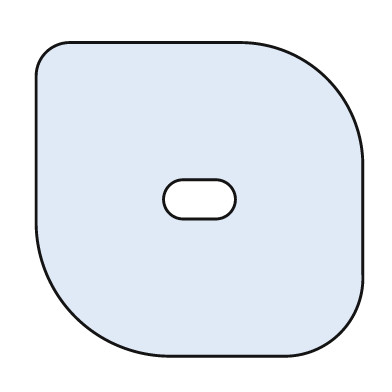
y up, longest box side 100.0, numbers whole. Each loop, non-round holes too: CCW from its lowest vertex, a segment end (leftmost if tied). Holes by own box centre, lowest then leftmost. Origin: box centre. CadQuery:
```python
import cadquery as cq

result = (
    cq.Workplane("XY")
    .moveTo(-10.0, -48.0)
    .lineTo(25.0, -48.0)
    .threePointArc((43.0, -41.0), (50.0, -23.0))
    .lineTo(50.0, 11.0)
    .threePointArc((39.0, 37.0), (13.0, 48.0))
    .lineTo(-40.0, 48.0)
    .threePointArc((-47.0, 45.0), (-50.0, 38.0))
    .lineTo(-50.0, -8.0)
    .threePointArc((-38.0, -36.0), (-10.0, -48.0))
    .close()
    .moveTo(-5.0, -6.0)
    .lineTo(5.0, -6.0)
    .threePointArc((11.0, 0.0), (5.0, 6.0))
    .lineTo(-5.0, 6.0)
    .threePointArc((-11.0, 0.0), (-5.0, -6.0))
    .close()
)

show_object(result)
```